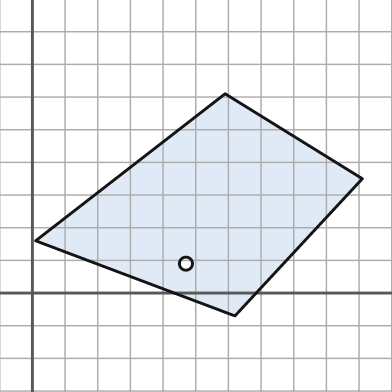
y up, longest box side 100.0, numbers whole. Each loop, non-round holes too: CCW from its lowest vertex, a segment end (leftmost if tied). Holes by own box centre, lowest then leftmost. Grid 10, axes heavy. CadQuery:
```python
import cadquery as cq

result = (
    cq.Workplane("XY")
    .moveTo(62.0, -7.0)
    .lineTo(101.0, 35.0)
    .lineTo(59.0, 61.0)
    .lineTo(1.0, 16.0)
    .close()
    .moveTo(47.0, 9.0)
    .circle(2.0)
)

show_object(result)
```